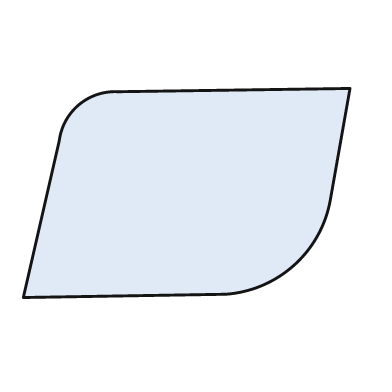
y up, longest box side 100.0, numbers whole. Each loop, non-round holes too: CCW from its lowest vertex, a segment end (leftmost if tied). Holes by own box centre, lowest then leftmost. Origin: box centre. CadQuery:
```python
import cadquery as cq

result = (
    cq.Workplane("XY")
    .moveTo(-50.0, -32.0)
    .lineTo(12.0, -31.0)
    .threePointArc((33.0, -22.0), (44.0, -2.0))
    .lineTo(50.0, 32.0)
    .lineTo(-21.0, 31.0)
    .threePointArc((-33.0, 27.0), (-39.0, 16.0))
    .close()
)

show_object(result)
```